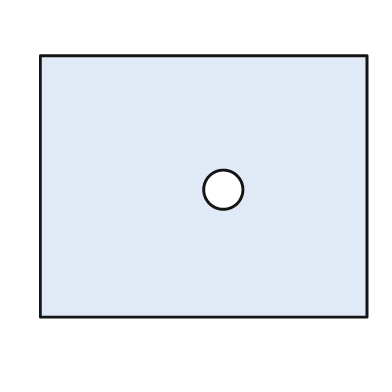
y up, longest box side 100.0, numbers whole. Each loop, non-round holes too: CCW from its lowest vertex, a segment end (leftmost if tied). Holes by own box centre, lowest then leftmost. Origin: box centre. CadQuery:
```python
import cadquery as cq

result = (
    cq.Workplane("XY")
    .moveTo(-50.0, -40.0)
    .lineTo(50.0, -40.0)
    .lineTo(50.0, 40.0)
    .lineTo(-50.0, 40.0)
    .close()
    .moveTo(6.0, -1.0)
    .circle(6.0)
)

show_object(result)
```